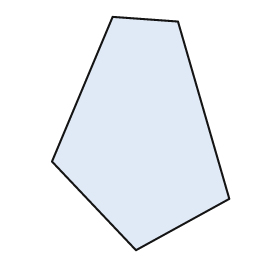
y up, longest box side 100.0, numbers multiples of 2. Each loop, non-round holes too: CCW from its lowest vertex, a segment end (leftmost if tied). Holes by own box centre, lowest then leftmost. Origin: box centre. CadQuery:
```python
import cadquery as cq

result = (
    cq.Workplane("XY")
    .moveTo(-2.0, -50.0)
    .lineTo(38.0, -28.0)
    .lineTo(16.0, 48.0)
    .lineTo(-12.0, 50.0)
    .lineTo(-38.0, -12.0)
    .close()
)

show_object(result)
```